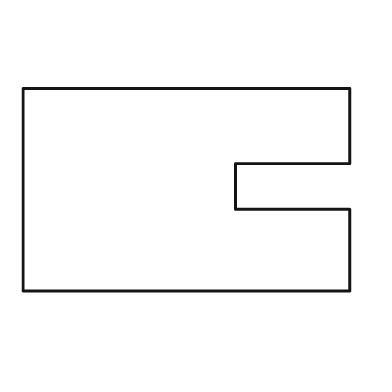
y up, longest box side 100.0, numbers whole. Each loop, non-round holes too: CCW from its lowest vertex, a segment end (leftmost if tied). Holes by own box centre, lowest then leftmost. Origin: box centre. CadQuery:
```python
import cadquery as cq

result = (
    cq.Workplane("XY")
    .moveTo(-50.0, -31.0)
    .lineTo(50.0, -31.0)
    .lineTo(50.0, -6.0)
    .lineTo(15.0, -6.0)
    .lineTo(15.0, 8.0)
    .lineTo(50.0, 8.0)
    .lineTo(50.0, 31.0)
    .lineTo(-50.0, 31.0)
    .close()
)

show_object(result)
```